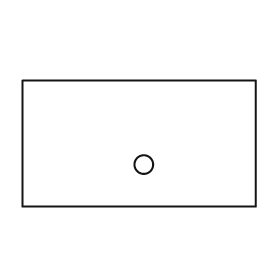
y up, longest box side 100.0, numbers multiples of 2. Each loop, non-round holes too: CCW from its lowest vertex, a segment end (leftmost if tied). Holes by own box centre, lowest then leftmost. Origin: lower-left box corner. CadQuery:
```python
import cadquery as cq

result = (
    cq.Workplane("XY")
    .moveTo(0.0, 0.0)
    .lineTo(100.0, 0.0)
    .lineTo(100.0, 54.0)
    .lineTo(0.0, 54.0)
    .close()
    .moveTo(52.0, 18.0)
    .circle(4.0)
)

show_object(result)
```